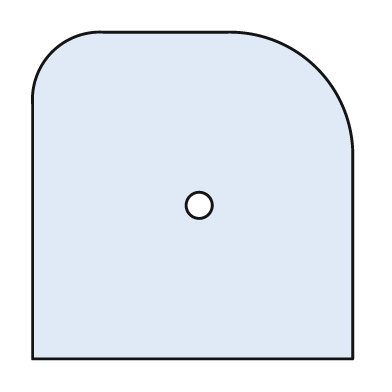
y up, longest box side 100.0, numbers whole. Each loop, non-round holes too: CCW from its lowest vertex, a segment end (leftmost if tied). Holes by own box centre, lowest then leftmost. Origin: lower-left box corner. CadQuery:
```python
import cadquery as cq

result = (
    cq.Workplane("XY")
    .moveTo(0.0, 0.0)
    .lineTo(98.0, 0.0)
    .lineTo(98.0, 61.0)
    .threePointArc((87.0, 89.0), (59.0, 100.0))
    .lineTo(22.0, 100.0)
    .threePointArc((6.0, 94.0), (0.0, 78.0))
    .close()
    .moveTo(51.0, 47.0)
    .circle(4.0)
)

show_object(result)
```